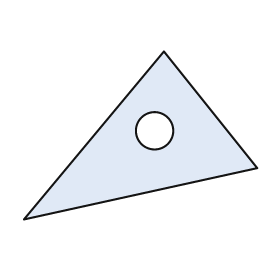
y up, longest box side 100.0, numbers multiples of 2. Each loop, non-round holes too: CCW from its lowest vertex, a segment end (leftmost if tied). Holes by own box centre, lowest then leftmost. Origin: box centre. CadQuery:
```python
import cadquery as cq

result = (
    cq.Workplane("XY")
    .moveTo(-50.0, -36.0)
    .lineTo(50.0, -14.0)
    .lineTo(10.0, 36.0)
    .close()
    .moveTo(6.0, 2.0)
    .circle(8.0)
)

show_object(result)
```